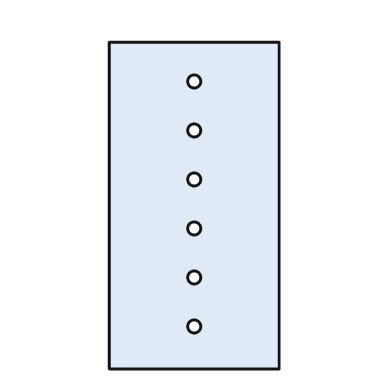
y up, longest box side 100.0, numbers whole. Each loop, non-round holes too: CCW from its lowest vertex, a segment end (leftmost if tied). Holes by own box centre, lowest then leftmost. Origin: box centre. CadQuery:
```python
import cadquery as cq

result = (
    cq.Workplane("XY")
    .moveTo(-26.0, -50.0)
    .lineTo(26.0, -50.0)
    .lineTo(26.0, 50.0)
    .lineTo(-26.0, 50.0)
    .close()
    .moveTo(0.0, -37.0)
    .circle(2.0)
    .moveTo(0.0, -22.0)
    .circle(2.0)
    .moveTo(0.0, -7.0)
    .circle(2.0)
    .moveTo(0.0, 8.0)
    .circle(2.0)
    .moveTo(0.0, 23.0)
    .circle(2.0)
    .moveTo(0.0, 38.0)
    .circle(2.0)
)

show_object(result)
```